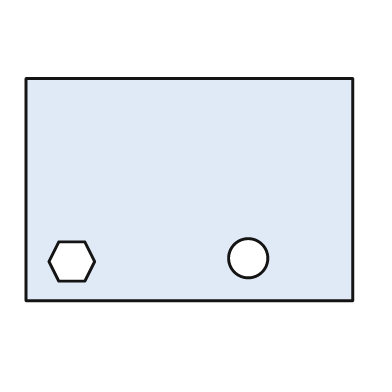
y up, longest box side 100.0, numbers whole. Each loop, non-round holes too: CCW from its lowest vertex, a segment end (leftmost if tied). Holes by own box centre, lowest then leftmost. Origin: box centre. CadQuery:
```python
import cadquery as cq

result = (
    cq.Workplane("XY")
    .moveTo(-50.0, -34.0)
    .lineTo(50.0, -34.0)
    .lineTo(50.0, 34.0)
    .lineTo(-50.0, 34.0)
    .close()
    .moveTo(-40.0, -28.0)
    .lineTo(-32.0, -28.0)
    .lineTo(-29.0, -22.0)
    .lineTo(-32.0, -16.0)
    .lineTo(-40.0, -16.0)
    .lineTo(-43.0, -22.0)
    .close()
    .moveTo(18.0, -21.0)
    .circle(6.0)
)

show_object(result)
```